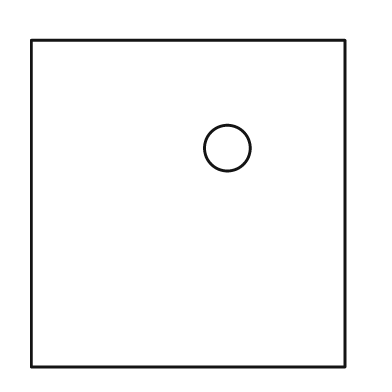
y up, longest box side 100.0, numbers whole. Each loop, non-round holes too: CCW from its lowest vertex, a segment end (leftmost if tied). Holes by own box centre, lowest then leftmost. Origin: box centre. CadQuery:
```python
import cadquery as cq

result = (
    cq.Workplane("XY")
    .moveTo(-48.0, -50.0)
    .lineTo(48.0, -50.0)
    .lineTo(48.0, 50.0)
    .lineTo(-48.0, 50.0)
    .close()
    .moveTo(12.0, 17.0)
    .circle(7.0)
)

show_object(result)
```